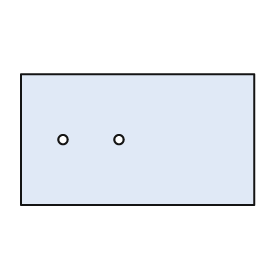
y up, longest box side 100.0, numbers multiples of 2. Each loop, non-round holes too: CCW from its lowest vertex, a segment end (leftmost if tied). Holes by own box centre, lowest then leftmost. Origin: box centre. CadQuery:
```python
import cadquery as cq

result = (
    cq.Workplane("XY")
    .moveTo(-50.0, -28.0)
    .lineTo(50.0, -28.0)
    .lineTo(50.0, 28.0)
    .lineTo(-50.0, 28.0)
    .close()
    .moveTo(-32.0, 0.0)
    .circle(2.0)
    .moveTo(-8.0, 0.0)
    .circle(2.0)
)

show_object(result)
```